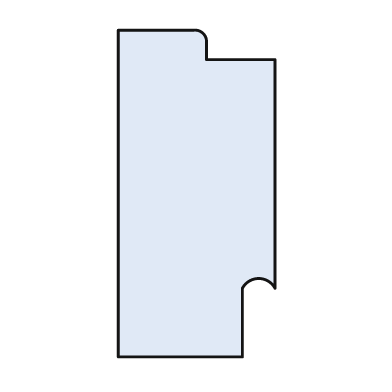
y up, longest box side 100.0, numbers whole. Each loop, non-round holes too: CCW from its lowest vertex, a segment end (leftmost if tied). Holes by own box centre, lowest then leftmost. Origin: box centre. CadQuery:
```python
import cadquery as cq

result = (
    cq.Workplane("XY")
    .moveTo(-24.0, -50.0)
    .lineTo(14.0, -50.0)
    .lineTo(14.0, -29.0)
    .threePointArc((19.0, -26.0), (24.0, -29.0))
    .lineTo(24.0, 41.0)
    .lineTo(3.0, 41.0)
    .lineTo(3.0, 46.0)
    .threePointArc((2.0, 49.0), (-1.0, 50.0))
    .lineTo(-24.0, 50.0)
    .close()
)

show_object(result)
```